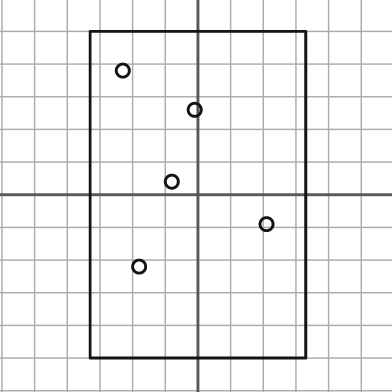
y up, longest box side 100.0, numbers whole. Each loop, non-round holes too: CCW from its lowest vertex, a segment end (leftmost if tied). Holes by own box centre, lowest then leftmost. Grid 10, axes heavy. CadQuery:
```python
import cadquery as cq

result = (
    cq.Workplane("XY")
    .moveTo(-33.0, -50.0)
    .lineTo(33.0, -50.0)
    .lineTo(33.0, 50.0)
    .lineTo(-33.0, 50.0)
    .close()
    .moveTo(-18.0, -22.0)
    .circle(2.0)
    .moveTo(21.0, -9.0)
    .circle(2.0)
    .moveTo(-8.0, 4.0)
    .circle(2.0)
    .moveTo(-1.0, 26.0)
    .circle(2.0)
    .moveTo(-23.0, 38.0)
    .circle(2.0)
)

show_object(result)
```